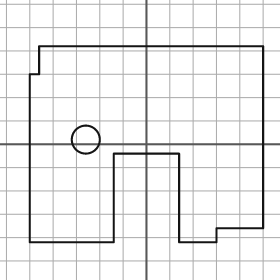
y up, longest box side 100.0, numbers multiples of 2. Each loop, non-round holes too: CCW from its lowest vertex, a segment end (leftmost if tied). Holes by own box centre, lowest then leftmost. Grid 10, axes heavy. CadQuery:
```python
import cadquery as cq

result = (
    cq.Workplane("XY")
    .moveTo(-50.0, -42.0)
    .lineTo(-14.0, -42.0)
    .lineTo(-14.0, -4.0)
    .lineTo(14.0, -4.0)
    .lineTo(14.0, -42.0)
    .lineTo(30.0, -42.0)
    .lineTo(30.0, -36.0)
    .lineTo(50.0, -36.0)
    .lineTo(50.0, 42.0)
    .lineTo(-46.0, 42.0)
    .lineTo(-46.0, 30.0)
    .lineTo(-50.0, 30.0)
    .close()
    .moveTo(-26.0, 2.0)
    .circle(6.0)
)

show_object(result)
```